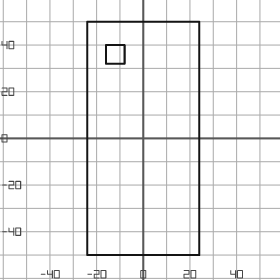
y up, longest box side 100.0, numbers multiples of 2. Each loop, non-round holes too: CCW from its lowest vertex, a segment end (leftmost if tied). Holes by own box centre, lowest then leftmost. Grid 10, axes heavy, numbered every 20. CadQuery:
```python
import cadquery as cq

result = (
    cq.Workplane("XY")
    .moveTo(-24.0, -50.0)
    .lineTo(24.0, -50.0)
    .lineTo(24.0, 50.0)
    .lineTo(-24.0, 50.0)
    .close()
    .moveTo(-16.0, 32.0)
    .lineTo(-8.0, 32.0)
    .lineTo(-8.0, 40.0)
    .lineTo(-16.0, 40.0)
    .close()
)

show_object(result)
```